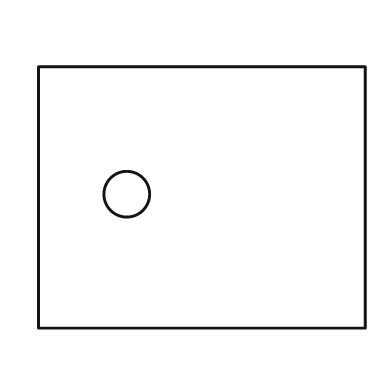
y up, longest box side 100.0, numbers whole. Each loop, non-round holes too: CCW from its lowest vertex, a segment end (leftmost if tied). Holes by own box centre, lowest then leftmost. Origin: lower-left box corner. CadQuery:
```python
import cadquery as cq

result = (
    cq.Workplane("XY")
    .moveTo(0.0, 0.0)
    .lineTo(100.0, 0.0)
    .lineTo(100.0, 80.0)
    .lineTo(0.0, 80.0)
    .close()
    .moveTo(27.0, 41.0)
    .circle(7.0)
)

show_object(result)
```